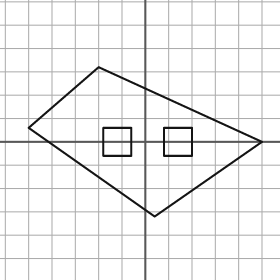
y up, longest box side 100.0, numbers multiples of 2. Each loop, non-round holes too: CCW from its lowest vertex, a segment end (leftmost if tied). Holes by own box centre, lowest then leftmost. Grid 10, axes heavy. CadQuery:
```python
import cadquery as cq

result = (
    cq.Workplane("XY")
    .moveTo(4.0, -32.0)
    .lineTo(50.0, 0.0)
    .lineTo(-20.0, 32.0)
    .lineTo(-50.0, 6.0)
    .close()
    .moveTo(-18.0, -6.0)
    .lineTo(-6.0, -6.0)
    .lineTo(-6.0, 6.0)
    .lineTo(-18.0, 6.0)
    .close()
    .moveTo(8.0, -6.0)
    .lineTo(20.0, -6.0)
    .lineTo(20.0, 6.0)
    .lineTo(8.0, 6.0)
    .close()
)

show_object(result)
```